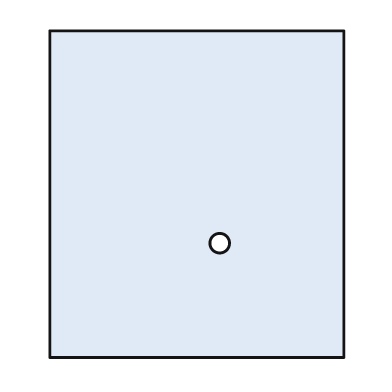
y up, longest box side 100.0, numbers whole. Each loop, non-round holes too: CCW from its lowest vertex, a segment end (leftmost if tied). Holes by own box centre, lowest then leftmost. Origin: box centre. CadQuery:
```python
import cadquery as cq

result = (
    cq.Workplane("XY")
    .moveTo(-45.0, -50.0)
    .lineTo(45.0, -50.0)
    .lineTo(45.0, 50.0)
    .lineTo(-45.0, 50.0)
    .close()
    .moveTo(7.0, -15.0)
    .circle(3.0)
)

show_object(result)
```